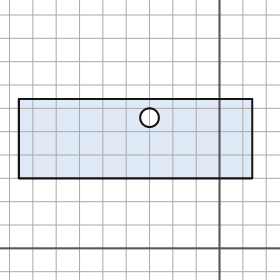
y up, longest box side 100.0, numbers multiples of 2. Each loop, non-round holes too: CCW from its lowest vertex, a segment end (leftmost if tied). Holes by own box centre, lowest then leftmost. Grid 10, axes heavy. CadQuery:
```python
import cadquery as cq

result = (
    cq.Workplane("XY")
    .moveTo(-86.0, 30.0)
    .lineTo(14.0, 30.0)
    .lineTo(14.0, 64.0)
    .lineTo(-86.0, 64.0)
    .close()
    .moveTo(-30.0, 56.0)
    .circle(4.0)
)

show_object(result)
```